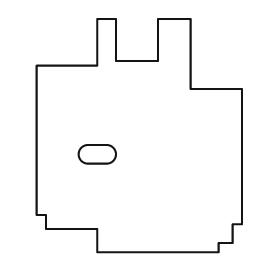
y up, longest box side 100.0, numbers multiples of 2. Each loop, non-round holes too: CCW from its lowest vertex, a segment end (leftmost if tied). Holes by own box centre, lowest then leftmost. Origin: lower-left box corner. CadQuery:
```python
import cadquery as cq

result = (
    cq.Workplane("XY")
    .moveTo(26.0, 0.0)
    .lineTo(78.0, 0.0)
    .lineTo(78.0, 4.0)
    .lineTo(84.0, 4.0)
    .lineTo(84.0, 12.0)
    .lineTo(88.0, 12.0)
    .lineTo(88.0, 70.0)
    .lineTo(66.0, 70.0)
    .lineTo(66.0, 100.0)
    .lineTo(52.0, 100.0)
    .lineTo(52.0, 82.0)
    .lineTo(34.0, 82.0)
    .lineTo(34.0, 100.0)
    .lineTo(26.0, 100.0)
    .lineTo(26.0, 80.0)
    .lineTo(0.0, 80.0)
    .lineTo(0.0, 16.0)
    .lineTo(4.0, 16.0)
    .lineTo(4.0, 10.0)
    .lineTo(26.0, 10.0)
    .close()
    .moveTo(22.0, 38.0)
    .lineTo(30.0, 38.0)
    .threePointArc((34.0, 42.0), (30.0, 46.0))
    .lineTo(22.0, 46.0)
    .threePointArc((18.0, 42.0), (22.0, 38.0))
    .close()
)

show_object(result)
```